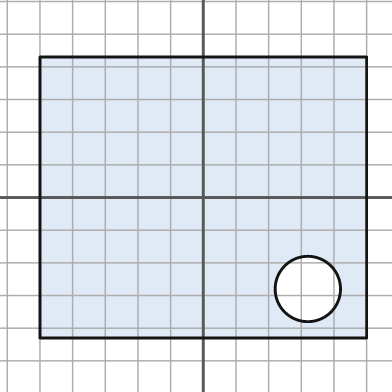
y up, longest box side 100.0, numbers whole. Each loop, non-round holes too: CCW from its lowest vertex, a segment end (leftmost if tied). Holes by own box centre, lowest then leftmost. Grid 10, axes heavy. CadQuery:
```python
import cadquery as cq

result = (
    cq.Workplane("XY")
    .moveTo(-50.0, -43.0)
    .lineTo(50.0, -43.0)
    .lineTo(50.0, 43.0)
    .lineTo(-50.0, 43.0)
    .close()
    .moveTo(32.0, -28.0)
    .circle(10.0)
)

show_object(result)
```